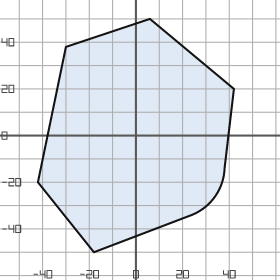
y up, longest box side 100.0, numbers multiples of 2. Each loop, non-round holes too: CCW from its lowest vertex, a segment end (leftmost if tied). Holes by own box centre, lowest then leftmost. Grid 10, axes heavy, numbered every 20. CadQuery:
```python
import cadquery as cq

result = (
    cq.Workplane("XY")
    .moveTo(-18.0, -50.0)
    .lineTo(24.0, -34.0)
    .threePointArc((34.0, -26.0), (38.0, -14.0))
    .lineTo(42.0, 20.0)
    .lineTo(6.0, 50.0)
    .lineTo(-30.0, 38.0)
    .lineTo(-42.0, -20.0)
    .close()
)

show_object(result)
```